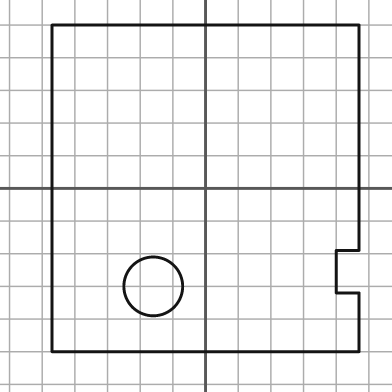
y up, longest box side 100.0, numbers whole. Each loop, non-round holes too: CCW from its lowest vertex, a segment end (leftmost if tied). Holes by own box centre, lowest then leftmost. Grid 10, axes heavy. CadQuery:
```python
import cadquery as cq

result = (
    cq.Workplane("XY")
    .moveTo(-47.0, -50.0)
    .lineTo(47.0, -50.0)
    .lineTo(47.0, -32.0)
    .lineTo(40.0, -32.0)
    .lineTo(40.0, -19.0)
    .lineTo(47.0, -19.0)
    .lineTo(47.0, 50.0)
    .lineTo(-47.0, 50.0)
    .close()
    .moveTo(-16.0, -30.0)
    .circle(9.0)
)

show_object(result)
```